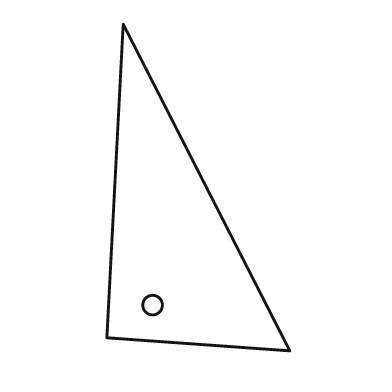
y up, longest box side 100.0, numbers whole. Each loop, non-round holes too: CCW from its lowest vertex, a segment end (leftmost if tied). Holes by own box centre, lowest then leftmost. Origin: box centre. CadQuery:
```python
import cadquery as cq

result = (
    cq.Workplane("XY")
    .moveTo(28.0, -50.0)
    .lineTo(-23.0, 50.0)
    .lineTo(-28.0, -46.0)
    .close()
    .moveTo(-14.0, -36.0)
    .circle(3.0)
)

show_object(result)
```